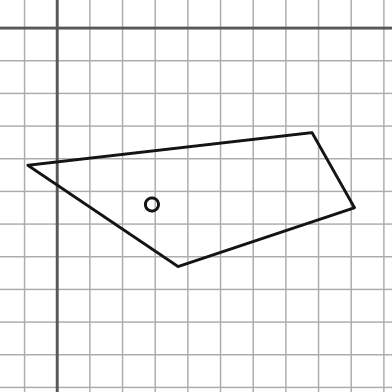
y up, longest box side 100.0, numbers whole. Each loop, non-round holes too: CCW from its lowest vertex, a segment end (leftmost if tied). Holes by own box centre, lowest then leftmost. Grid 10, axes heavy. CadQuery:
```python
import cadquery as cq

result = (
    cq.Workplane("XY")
    .moveTo(37.0, -73.0)
    .lineTo(91.0, -55.0)
    .lineTo(78.0, -32.0)
    .lineTo(-9.0, -42.0)
    .close()
    .moveTo(29.0, -54.0)
    .circle(2.0)
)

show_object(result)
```